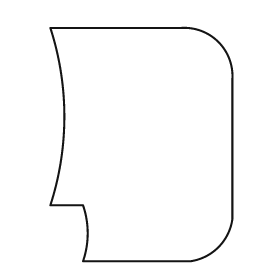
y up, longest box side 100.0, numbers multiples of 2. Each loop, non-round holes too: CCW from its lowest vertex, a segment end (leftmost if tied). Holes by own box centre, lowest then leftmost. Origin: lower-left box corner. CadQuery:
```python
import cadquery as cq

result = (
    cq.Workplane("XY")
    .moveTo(14.0, 0.0)
    .lineTo(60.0, 0.0)
    .threePointArc((72.0, 6.0), (78.0, 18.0))
    .lineTo(78.0, 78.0)
    .threePointArc((72.0, 94.0), (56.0, 100.0))
    .lineTo(0.0, 100.0)
    .threePointArc((6.0, 62.0), (0.0, 24.0))
    .lineTo(14.0, 24.0)
    .threePointArc((16.0, 12.0), (14.0, 0.0))
    .close()
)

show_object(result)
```